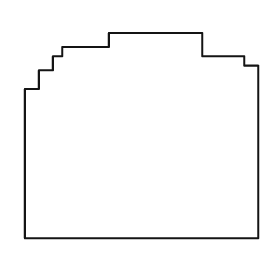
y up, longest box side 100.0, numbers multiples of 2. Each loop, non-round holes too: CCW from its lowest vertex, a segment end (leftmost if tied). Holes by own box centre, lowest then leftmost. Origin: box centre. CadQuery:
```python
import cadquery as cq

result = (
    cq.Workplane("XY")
    .moveTo(-50.0, -44.0)
    .lineTo(50.0, -44.0)
    .lineTo(50.0, 30.0)
    .lineTo(44.0, 30.0)
    .lineTo(44.0, 34.0)
    .lineTo(26.0, 34.0)
    .lineTo(26.0, 44.0)
    .lineTo(-14.0, 44.0)
    .lineTo(-14.0, 38.0)
    .lineTo(-34.0, 38.0)
    .lineTo(-34.0, 34.0)
    .lineTo(-38.0, 34.0)
    .lineTo(-38.0, 28.0)
    .lineTo(-44.0, 28.0)
    .lineTo(-44.0, 20.0)
    .lineTo(-50.0, 20.0)
    .close()
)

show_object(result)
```